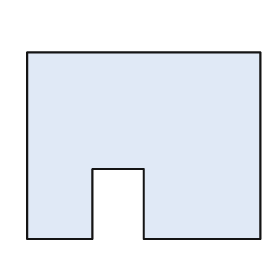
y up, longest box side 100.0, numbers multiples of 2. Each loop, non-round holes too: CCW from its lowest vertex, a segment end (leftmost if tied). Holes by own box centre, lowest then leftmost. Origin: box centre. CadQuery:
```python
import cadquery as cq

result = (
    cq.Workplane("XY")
    .moveTo(-50.0, -40.0)
    .lineTo(-22.0, -40.0)
    .lineTo(-22.0, -10.0)
    .lineTo(0.0, -10.0)
    .lineTo(0.0, -40.0)
    .lineTo(50.0, -40.0)
    .lineTo(50.0, 40.0)
    .lineTo(-50.0, 40.0)
    .close()
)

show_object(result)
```